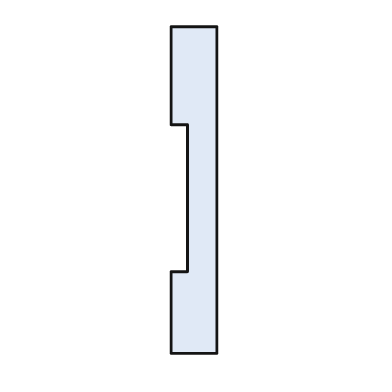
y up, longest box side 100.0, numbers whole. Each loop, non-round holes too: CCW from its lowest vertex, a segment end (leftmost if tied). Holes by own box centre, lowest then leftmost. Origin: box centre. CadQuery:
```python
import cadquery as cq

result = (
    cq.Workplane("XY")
    .moveTo(-7.0, -50.0)
    .lineTo(7.0, -50.0)
    .lineTo(7.0, 50.0)
    .lineTo(-7.0, 50.0)
    .lineTo(-7.0, 20.0)
    .lineTo(-2.0, 20.0)
    .lineTo(-2.0, -25.0)
    .lineTo(-7.0, -25.0)
    .close()
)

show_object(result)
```